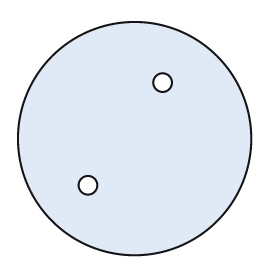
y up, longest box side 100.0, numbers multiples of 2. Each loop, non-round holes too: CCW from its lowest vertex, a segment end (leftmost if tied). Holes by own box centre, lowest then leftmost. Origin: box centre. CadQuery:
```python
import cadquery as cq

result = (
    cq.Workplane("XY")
    .moveTo(0.0, 0.0)
    .circle(50.0)
    .moveTo(-20.0, -20.0)
    .circle(4.0)
    .moveTo(12.0, 24.0)
    .circle(4.0)
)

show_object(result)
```